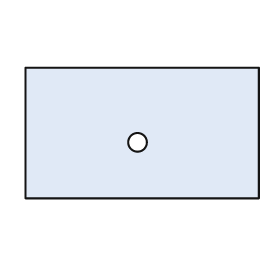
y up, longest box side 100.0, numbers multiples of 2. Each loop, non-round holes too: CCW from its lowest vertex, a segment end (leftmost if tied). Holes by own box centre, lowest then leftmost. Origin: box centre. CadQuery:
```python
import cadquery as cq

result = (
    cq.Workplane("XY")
    .moveTo(-50.0, -28.0)
    .lineTo(50.0, -28.0)
    .lineTo(50.0, 28.0)
    .lineTo(-50.0, 28.0)
    .close()
    .moveTo(-2.0, -4.0)
    .circle(4.0)
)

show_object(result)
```